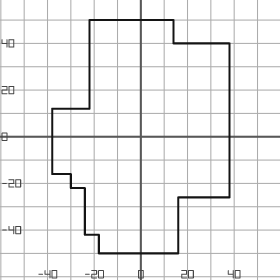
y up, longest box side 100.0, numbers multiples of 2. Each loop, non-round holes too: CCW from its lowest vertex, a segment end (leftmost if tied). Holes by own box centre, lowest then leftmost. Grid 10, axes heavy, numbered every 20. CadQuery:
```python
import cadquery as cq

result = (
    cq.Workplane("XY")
    .moveTo(-18.0, -50.0)
    .lineTo(16.0, -50.0)
    .lineTo(16.0, -26.0)
    .lineTo(38.0, -26.0)
    .lineTo(38.0, 40.0)
    .lineTo(14.0, 40.0)
    .lineTo(14.0, 50.0)
    .lineTo(-22.0, 50.0)
    .lineTo(-22.0, 12.0)
    .lineTo(-38.0, 12.0)
    .lineTo(-38.0, -16.0)
    .lineTo(-30.0, -16.0)
    .lineTo(-30.0, -22.0)
    .lineTo(-24.0, -22.0)
    .lineTo(-24.0, -42.0)
    .lineTo(-18.0, -42.0)
    .close()
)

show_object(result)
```